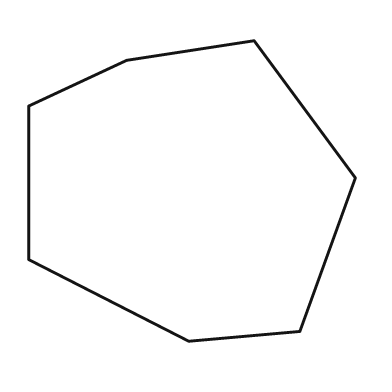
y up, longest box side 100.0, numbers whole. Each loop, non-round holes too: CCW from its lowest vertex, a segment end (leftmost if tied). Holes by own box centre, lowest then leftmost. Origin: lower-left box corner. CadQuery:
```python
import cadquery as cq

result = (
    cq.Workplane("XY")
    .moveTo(49.0, 0.0)
    .lineTo(83.0, 3.0)
    .lineTo(100.0, 50.0)
    .lineTo(69.0, 92.0)
    .lineTo(30.0, 86.0)
    .lineTo(0.0, 72.0)
    .lineTo(0.0, 25.0)
    .close()
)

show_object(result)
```